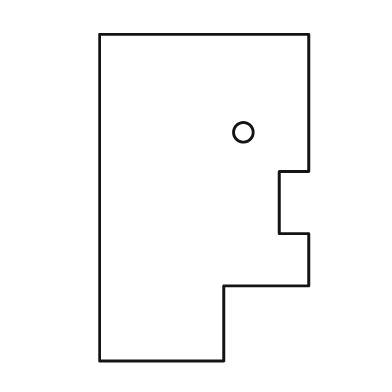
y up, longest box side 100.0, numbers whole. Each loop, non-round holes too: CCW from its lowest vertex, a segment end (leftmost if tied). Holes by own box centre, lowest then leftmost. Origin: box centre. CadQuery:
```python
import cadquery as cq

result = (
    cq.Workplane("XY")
    .moveTo(-32.0, -50.0)
    .lineTo(6.0, -50.0)
    .lineTo(6.0, -27.0)
    .lineTo(32.0, -27.0)
    .lineTo(32.0, -11.0)
    .lineTo(23.0, -11.0)
    .lineTo(23.0, 8.0)
    .lineTo(32.0, 8.0)
    .lineTo(32.0, 50.0)
    .lineTo(-32.0, 50.0)
    .close()
    .moveTo(12.0, 20.0)
    .circle(3.0)
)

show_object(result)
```